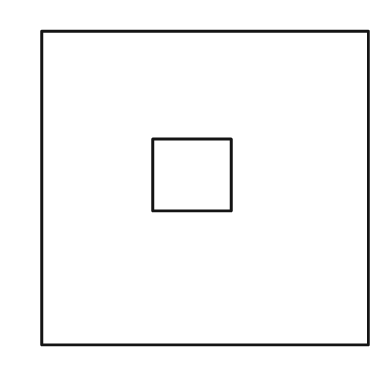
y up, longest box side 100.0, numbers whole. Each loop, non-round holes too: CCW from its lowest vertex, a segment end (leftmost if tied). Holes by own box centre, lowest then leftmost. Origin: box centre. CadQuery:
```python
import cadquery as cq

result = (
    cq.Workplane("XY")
    .moveTo(-50.0, -48.0)
    .lineTo(50.0, -48.0)
    .lineTo(50.0, 48.0)
    .lineTo(-50.0, 48.0)
    .close()
    .moveTo(-16.0, -7.0)
    .lineTo(8.0, -7.0)
    .lineTo(8.0, 15.0)
    .lineTo(-16.0, 15.0)
    .close()
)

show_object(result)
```